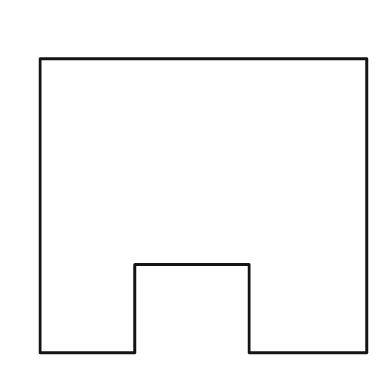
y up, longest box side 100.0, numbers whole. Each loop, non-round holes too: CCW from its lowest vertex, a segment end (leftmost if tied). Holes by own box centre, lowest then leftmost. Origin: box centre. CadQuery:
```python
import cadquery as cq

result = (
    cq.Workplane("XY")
    .moveTo(-50.0, -45.0)
    .lineTo(-21.0, -45.0)
    .lineTo(-21.0, -18.0)
    .lineTo(14.0, -18.0)
    .lineTo(14.0, -45.0)
    .lineTo(50.0, -45.0)
    .lineTo(50.0, 45.0)
    .lineTo(-50.0, 45.0)
    .close()
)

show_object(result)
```